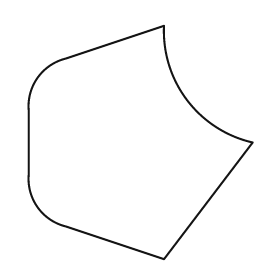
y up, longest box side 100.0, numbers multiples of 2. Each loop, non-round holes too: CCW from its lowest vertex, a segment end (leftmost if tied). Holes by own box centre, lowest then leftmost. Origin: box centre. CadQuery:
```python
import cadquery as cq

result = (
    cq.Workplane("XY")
    .moveTo(10.0, -50.0)
    .lineTo(48.0, 0.0)
    .threePointArc((20.0, 18.0), (10.0, 50.0))
    .lineTo(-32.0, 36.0)
    .threePointArc((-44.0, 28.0), (-48.0, 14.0))
    .lineTo(-48.0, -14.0)
    .threePointArc((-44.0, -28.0), (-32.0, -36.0))
    .close()
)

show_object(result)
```